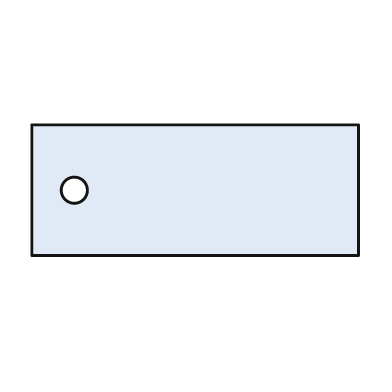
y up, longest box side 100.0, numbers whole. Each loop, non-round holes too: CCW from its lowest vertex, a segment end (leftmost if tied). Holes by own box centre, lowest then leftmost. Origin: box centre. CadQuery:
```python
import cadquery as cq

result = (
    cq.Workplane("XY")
    .moveTo(-50.0, -20.0)
    .lineTo(50.0, -20.0)
    .lineTo(50.0, 20.0)
    .lineTo(-50.0, 20.0)
    .close()
    .moveTo(-37.0, 0.0)
    .circle(4.0)
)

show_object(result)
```